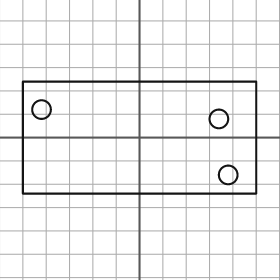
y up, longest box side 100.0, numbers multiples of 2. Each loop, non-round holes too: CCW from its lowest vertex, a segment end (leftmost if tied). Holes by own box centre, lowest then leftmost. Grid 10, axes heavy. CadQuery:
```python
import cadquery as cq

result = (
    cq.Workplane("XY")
    .moveTo(-50.0, -24.0)
    .lineTo(50.0, -24.0)
    .lineTo(50.0, 24.0)
    .lineTo(-50.0, 24.0)
    .close()
    .moveTo(38.0, -16.0)
    .circle(4.0)
    .moveTo(34.0, 8.0)
    .circle(4.0)
    .moveTo(-42.0, 12.0)
    .circle(4.0)
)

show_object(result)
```